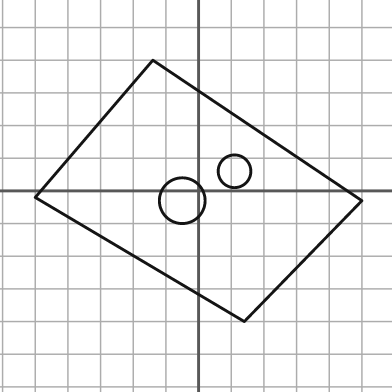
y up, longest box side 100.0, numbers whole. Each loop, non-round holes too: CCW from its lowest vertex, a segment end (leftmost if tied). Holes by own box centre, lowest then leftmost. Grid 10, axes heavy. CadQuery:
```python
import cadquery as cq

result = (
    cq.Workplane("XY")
    .moveTo(14.0, -40.0)
    .lineTo(50.0, -3.0)
    .lineTo(-14.0, 40.0)
    .lineTo(-50.0, -2.0)
    .close()
    .moveTo(-5.0, -3.0)
    .circle(7.0)
    .moveTo(11.0, 6.0)
    .circle(5.0)
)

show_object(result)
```